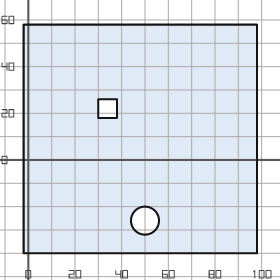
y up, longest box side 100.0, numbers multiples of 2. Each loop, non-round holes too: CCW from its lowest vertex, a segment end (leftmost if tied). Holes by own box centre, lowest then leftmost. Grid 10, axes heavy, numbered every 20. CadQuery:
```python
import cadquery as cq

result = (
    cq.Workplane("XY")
    .moveTo(-2.0, -40.0)
    .lineTo(98.0, -40.0)
    .lineTo(98.0, 58.0)
    .lineTo(-2.0, 58.0)
    .close()
    .moveTo(50.0, -26.0)
    .circle(6.0)
    .moveTo(30.0, 18.0)
    .lineTo(38.0, 18.0)
    .lineTo(38.0, 26.0)
    .lineTo(30.0, 26.0)
    .close()
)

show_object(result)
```